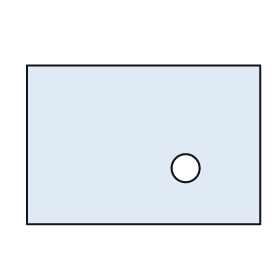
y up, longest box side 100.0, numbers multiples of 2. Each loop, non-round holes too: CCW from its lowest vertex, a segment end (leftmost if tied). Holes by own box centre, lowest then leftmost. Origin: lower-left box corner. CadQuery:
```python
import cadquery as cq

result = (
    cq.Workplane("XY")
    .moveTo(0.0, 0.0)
    .lineTo(100.0, 0.0)
    .lineTo(100.0, 68.0)
    .lineTo(0.0, 68.0)
    .close()
    .moveTo(68.0, 24.0)
    .circle(6.0)
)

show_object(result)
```